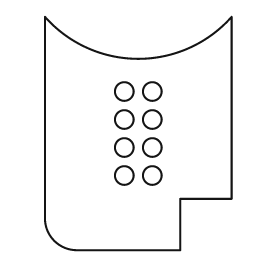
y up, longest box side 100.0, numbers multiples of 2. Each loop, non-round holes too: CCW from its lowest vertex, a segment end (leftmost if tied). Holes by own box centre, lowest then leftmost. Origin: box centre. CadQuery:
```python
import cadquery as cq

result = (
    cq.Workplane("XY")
    .moveTo(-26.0, -50.0)
    .lineTo(18.0, -50.0)
    .lineTo(18.0, -28.0)
    .lineTo(40.0, -28.0)
    .lineTo(40.0, 50.0)
    .threePointArc((0.0, 32.0), (-40.0, 50.0))
    .lineTo(-40.0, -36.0)
    .threePointArc((-36.0, -46.0), (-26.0, -50.0))
    .close()
    .moveTo(-6.0, -18.0)
    .circle(4.0)
    .moveTo(6.0, -18.0)
    .circle(4.0)
    .moveTo(-6.0, -6.0)
    .circle(4.0)
    .moveTo(6.0, -6.0)
    .circle(4.0)
    .moveTo(-6.0, 6.0)
    .circle(4.0)
    .moveTo(6.0, 6.0)
    .circle(4.0)
    .moveTo(-6.0, 18.0)
    .circle(4.0)
    .moveTo(6.0, 18.0)
    .circle(4.0)
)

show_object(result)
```